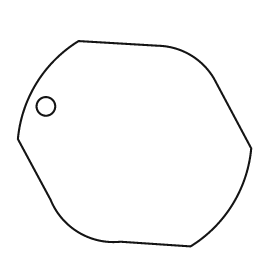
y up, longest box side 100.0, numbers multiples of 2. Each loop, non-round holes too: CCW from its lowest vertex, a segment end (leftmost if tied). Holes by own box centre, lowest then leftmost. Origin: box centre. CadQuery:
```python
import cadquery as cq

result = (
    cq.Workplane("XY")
    .moveTo(24.0, -44.0)
    .threePointArc((42.0, -26.0), (50.0, -2.0))
    .lineTo(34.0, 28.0)
    .threePointArc((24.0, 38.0), (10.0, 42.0))
    .lineTo(-24.0, 44.0)
    .threePointArc((-42.0, 26.0), (-50.0, 2.0))
    .lineTo(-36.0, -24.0)
    .threePointArc((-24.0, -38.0), (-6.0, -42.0))
    .close()
    .moveTo(-38.0, 16.0)
    .circle(4.0)
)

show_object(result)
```